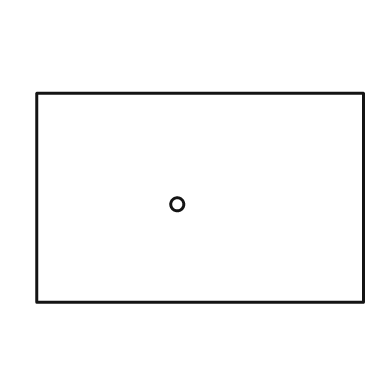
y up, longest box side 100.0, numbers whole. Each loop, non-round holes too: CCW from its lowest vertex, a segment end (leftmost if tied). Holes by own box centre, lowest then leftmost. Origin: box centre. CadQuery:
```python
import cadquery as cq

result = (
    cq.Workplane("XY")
    .moveTo(-50.0, -32.0)
    .lineTo(50.0, -32.0)
    .lineTo(50.0, 32.0)
    .lineTo(-50.0, 32.0)
    .close()
    .moveTo(-7.0, -2.0)
    .circle(2.0)
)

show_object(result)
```